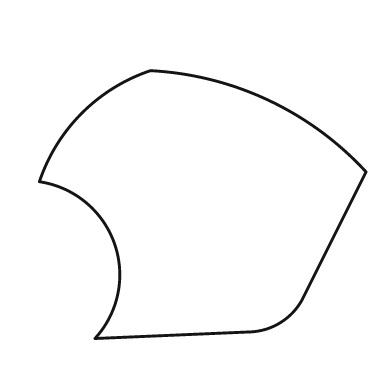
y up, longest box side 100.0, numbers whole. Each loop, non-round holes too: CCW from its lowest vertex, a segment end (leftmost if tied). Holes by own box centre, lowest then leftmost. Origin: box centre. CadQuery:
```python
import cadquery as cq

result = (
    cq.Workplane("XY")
    .moveTo(-33.0, -41.0)
    .lineTo(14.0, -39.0)
    .threePointArc((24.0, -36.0), (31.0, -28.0))
    .lineTo(50.0, 10.0)
    .threePointArc((20.0, 32.0), (-16.0, 41.0))
    .threePointArc((-37.0, 28.0), (-50.0, 7.0))
    .threePointArc((-27.0, -12.0), (-33.0, -41.0))
    .close()
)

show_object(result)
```